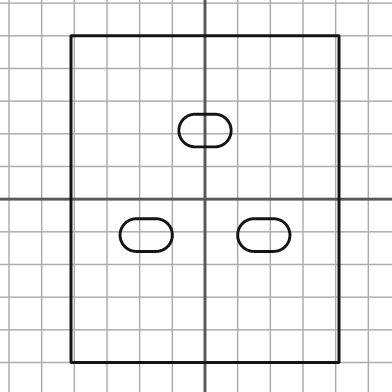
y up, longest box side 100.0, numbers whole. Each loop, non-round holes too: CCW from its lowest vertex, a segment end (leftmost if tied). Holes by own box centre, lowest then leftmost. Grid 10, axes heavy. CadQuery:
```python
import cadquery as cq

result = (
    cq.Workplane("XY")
    .moveTo(-41.0, -50.0)
    .lineTo(41.0, -50.0)
    .lineTo(41.0, 50.0)
    .lineTo(-41.0, 50.0)
    .close()
    .moveTo(-21.0, -16.0)
    .lineTo(-15.0, -16.0)
    .threePointArc((-10.0, -11.0), (-15.0, -6.0))
    .lineTo(-21.0, -6.0)
    .threePointArc((-26.0, -11.0), (-21.0, -16.0))
    .close()
    .moveTo(15.0, -16.0)
    .lineTo(21.0, -16.0)
    .threePointArc((26.0, -11.0), (21.0, -6.0))
    .lineTo(15.0, -6.0)
    .threePointArc((10.0, -11.0), (15.0, -16.0))
    .close()
    .moveTo(-3.0, 16.0)
    .lineTo(3.0, 16.0)
    .threePointArc((8.0, 21.0), (3.0, 26.0))
    .lineTo(-3.0, 26.0)
    .threePointArc((-8.0, 21.0), (-3.0, 16.0))
    .close()
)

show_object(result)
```